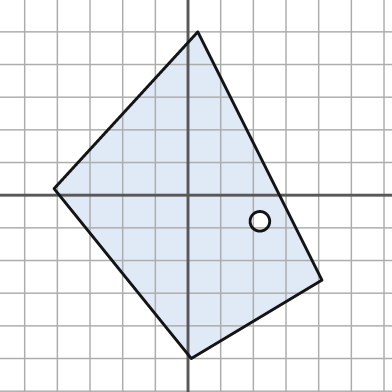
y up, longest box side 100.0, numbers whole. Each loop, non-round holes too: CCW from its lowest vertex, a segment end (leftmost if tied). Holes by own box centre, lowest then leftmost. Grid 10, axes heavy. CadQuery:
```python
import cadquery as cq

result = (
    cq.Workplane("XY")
    .moveTo(1.0, -50.0)
    .lineTo(41.0, -26.0)
    .lineTo(3.0, 50.0)
    .lineTo(-41.0, 2.0)
    .close()
    .moveTo(22.0, -8.0)
    .circle(3.0)
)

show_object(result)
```